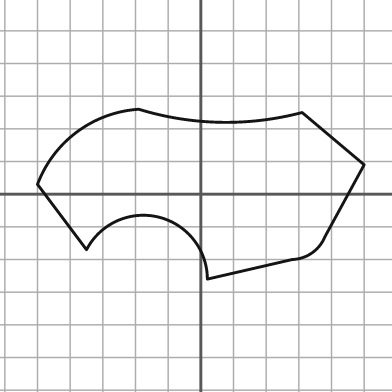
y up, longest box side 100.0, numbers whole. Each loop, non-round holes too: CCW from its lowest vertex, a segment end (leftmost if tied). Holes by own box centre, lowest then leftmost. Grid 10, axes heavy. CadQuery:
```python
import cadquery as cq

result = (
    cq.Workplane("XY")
    .moveTo(2.0, -26.0)
    .lineTo(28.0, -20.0)
    .threePointArc((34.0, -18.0), (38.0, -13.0))
    .lineTo(50.0, 9.0)
    .lineTo(31.0, 25.0)
    .threePointArc((6.0, 22.0), (-19.0, 26.0))
    .threePointArc((-38.0, 19.0), (-50.0, 3.0))
    .lineTo(-35.0, -17.0)
    .threePointArc((-13.0, -7.0), (2.0, -26.0))
    .close()
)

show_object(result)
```